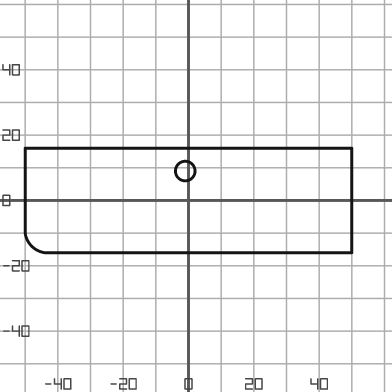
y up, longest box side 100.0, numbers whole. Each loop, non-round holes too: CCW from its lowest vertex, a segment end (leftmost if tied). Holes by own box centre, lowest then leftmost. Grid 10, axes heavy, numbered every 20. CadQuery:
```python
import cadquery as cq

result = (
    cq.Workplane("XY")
    .moveTo(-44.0, -16.0)
    .lineTo(50.0, -16.0)
    .lineTo(50.0, 16.0)
    .lineTo(-50.0, 16.0)
    .lineTo(-50.0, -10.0)
    .threePointArc((-48.0, -14.0), (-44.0, -16.0))
    .close()
    .moveTo(-1.0, 9.0)
    .circle(3.0)
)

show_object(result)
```